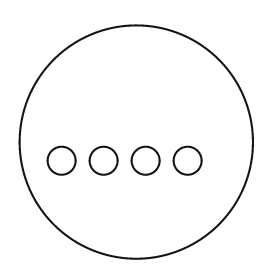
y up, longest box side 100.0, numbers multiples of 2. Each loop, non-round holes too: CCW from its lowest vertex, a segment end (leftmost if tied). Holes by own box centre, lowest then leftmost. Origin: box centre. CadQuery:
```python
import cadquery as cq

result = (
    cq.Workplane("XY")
    .moveTo(0.0, 0.0)
    .circle(50.0)
    .moveTo(-32.0, -8.0)
    .circle(6.0)
    .moveTo(-14.0, -8.0)
    .circle(6.0)
    .moveTo(4.0, -8.0)
    .circle(6.0)
    .moveTo(22.0, -8.0)
    .circle(6.0)
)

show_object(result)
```